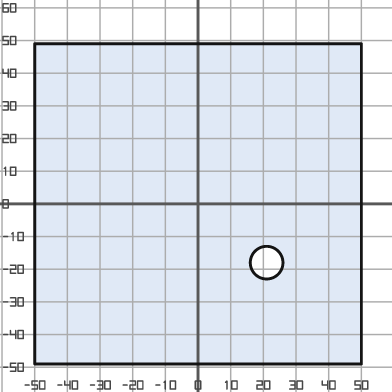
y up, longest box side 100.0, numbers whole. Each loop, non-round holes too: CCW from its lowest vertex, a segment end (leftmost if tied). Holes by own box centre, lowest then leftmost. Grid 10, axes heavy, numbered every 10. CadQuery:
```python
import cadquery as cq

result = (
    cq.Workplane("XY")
    .moveTo(-50.0, -49.0)
    .lineTo(50.0, -49.0)
    .lineTo(50.0, 49.0)
    .lineTo(-50.0, 49.0)
    .close()
    .moveTo(21.0, -18.0)
    .circle(5.0)
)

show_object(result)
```